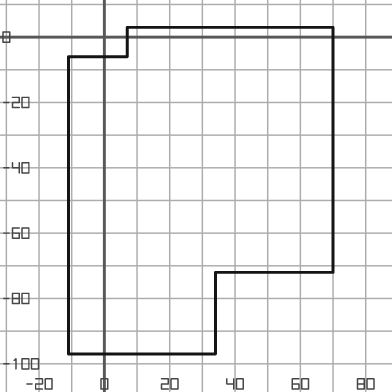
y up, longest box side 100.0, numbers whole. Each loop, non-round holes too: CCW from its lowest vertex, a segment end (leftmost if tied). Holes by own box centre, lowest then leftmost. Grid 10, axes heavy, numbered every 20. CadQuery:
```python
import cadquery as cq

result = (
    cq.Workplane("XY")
    .moveTo(-11.0, -97.0)
    .lineTo(34.0, -97.0)
    .lineTo(34.0, -72.0)
    .lineTo(70.0, -72.0)
    .lineTo(70.0, 3.0)
    .lineTo(7.0, 3.0)
    .lineTo(7.0, -6.0)
    .lineTo(-11.0, -6.0)
    .close()
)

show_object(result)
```